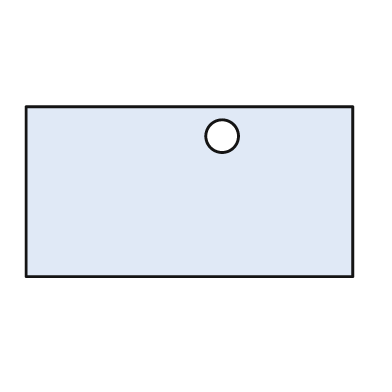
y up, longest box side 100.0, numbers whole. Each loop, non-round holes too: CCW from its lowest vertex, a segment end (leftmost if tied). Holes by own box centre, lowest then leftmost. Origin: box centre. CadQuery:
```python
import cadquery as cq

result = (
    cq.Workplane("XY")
    .moveTo(-50.0, -26.0)
    .lineTo(50.0, -26.0)
    .lineTo(50.0, 26.0)
    .lineTo(-50.0, 26.0)
    .close()
    .moveTo(10.0, 17.0)
    .circle(5.0)
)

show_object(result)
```